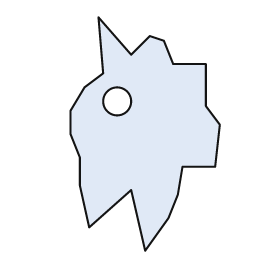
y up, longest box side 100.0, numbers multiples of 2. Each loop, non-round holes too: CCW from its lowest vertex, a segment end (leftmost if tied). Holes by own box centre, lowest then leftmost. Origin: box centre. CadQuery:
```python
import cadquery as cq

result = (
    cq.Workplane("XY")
    .moveTo(0.0, -50.0)
    .lineTo(10.0, -36.0)
    .lineTo(14.0, -26.0)
    .lineTo(16.0, -14.0)
    .lineTo(30.0, -14.0)
    .lineTo(32.0, 4.0)
    .lineTo(26.0, 12.0)
    .lineTo(26.0, 30.0)
    .lineTo(12.0, 30.0)
    .lineTo(8.0, 40.0)
    .lineTo(2.0, 42.0)
    .lineTo(-6.0, 34.0)
    .lineTo(-20.0, 50.0)
    .lineTo(-18.0, 26.0)
    .lineTo(-26.0, 20.0)
    .lineTo(-32.0, 10.0)
    .lineTo(-32.0, 0.0)
    .lineTo(-28.0, -10.0)
    .lineTo(-28.0, -22.0)
    .lineTo(-24.0, -40.0)
    .lineTo(-6.0, -24.0)
    .close()
    .moveTo(-12.0, 14.0)
    .circle(6.0)
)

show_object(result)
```